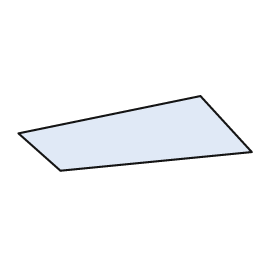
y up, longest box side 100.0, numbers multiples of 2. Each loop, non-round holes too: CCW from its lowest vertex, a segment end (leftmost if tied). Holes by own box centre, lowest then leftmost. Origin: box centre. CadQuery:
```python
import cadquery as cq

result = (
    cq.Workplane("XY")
    .moveTo(-32.0, -16.0)
    .lineTo(50.0, -8.0)
    .lineTo(28.0, 16.0)
    .lineTo(-50.0, 0.0)
    .close()
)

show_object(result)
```